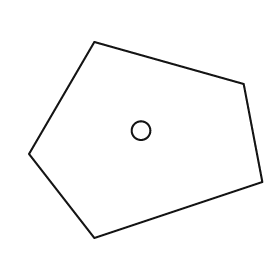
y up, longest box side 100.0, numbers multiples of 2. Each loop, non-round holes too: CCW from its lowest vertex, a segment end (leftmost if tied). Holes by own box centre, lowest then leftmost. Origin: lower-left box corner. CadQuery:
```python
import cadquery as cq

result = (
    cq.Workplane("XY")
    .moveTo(28.0, 0.0)
    .lineTo(100.0, 24.0)
    .lineTo(92.0, 66.0)
    .lineTo(28.0, 84.0)
    .lineTo(0.0, 36.0)
    .close()
    .moveTo(48.0, 46.0)
    .circle(4.0)
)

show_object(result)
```